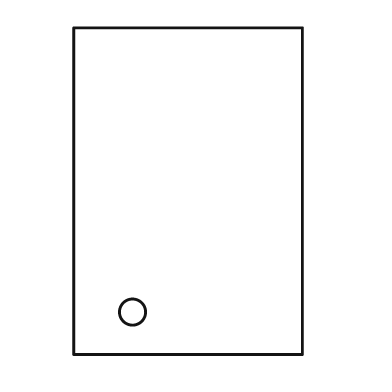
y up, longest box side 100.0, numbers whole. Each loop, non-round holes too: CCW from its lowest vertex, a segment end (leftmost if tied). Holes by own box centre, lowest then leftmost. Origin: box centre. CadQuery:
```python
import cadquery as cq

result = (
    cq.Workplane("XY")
    .moveTo(-35.0, -50.0)
    .lineTo(35.0, -50.0)
    .lineTo(35.0, 50.0)
    .lineTo(-35.0, 50.0)
    .close()
    .moveTo(-17.0, -37.0)
    .circle(4.0)
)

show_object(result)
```